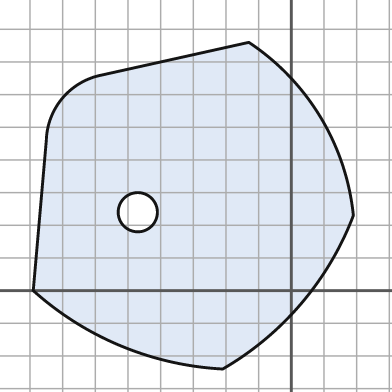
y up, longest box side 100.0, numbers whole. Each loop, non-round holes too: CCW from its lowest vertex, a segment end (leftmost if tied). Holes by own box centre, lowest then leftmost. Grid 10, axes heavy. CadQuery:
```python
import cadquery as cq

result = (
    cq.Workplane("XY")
    .moveTo(-21.0, -24.0)
    .threePointArc((3.0, -4.0), (19.0, 23.0))
    .threePointArc((9.0, 53.0), (-13.0, 76.0))
    .lineTo(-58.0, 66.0)
    .threePointArc((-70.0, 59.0), (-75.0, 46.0))
    .lineTo(-79.0, 0.0)
    .threePointArc((-52.0, -17.0), (-21.0, -24.0))
    .close()
    .moveTo(-47.0, 24.0)
    .circle(6.0)
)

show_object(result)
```